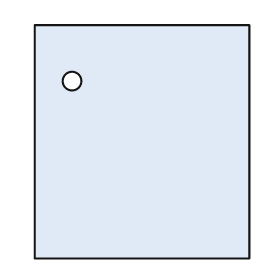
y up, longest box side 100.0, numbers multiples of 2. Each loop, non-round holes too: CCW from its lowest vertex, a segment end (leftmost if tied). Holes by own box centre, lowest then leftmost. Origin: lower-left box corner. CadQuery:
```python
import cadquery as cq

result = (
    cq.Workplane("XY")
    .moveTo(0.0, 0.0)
    .lineTo(92.0, 0.0)
    .lineTo(92.0, 100.0)
    .lineTo(0.0, 100.0)
    .close()
    .moveTo(16.0, 76.0)
    .circle(4.0)
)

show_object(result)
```